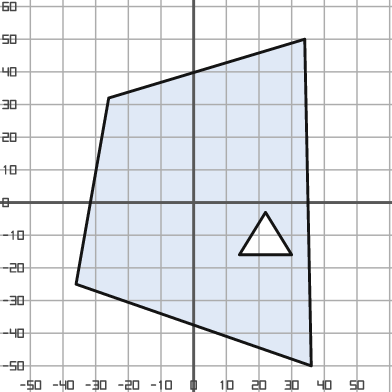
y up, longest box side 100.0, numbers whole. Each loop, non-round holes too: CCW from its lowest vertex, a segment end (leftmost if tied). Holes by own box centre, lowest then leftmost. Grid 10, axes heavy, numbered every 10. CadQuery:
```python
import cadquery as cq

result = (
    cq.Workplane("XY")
    .moveTo(36.0, -50.0)
    .lineTo(34.0, 50.0)
    .lineTo(-26.0, 32.0)
    .lineTo(-36.0, -25.0)
    .close()
    .moveTo(14.0, -16.0)
    .lineTo(30.0, -16.0)
    .lineTo(22.0, -3.0)
    .close()
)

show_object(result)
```